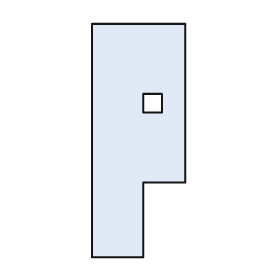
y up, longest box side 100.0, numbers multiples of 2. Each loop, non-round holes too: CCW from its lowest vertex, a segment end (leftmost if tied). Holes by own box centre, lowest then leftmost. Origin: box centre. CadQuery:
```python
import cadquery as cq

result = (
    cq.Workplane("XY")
    .moveTo(-20.0, -50.0)
    .lineTo(2.0, -50.0)
    .lineTo(2.0, -18.0)
    .lineTo(20.0, -18.0)
    .lineTo(20.0, 50.0)
    .lineTo(-20.0, 50.0)
    .close()
    .moveTo(2.0, 12.0)
    .lineTo(10.0, 12.0)
    .lineTo(10.0, 20.0)
    .lineTo(2.0, 20.0)
    .close()
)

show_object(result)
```